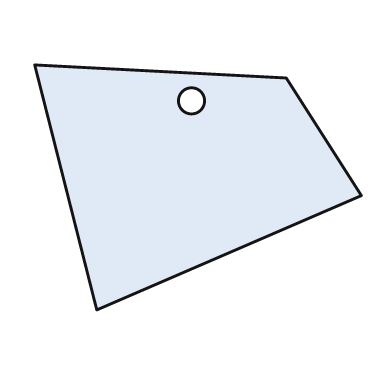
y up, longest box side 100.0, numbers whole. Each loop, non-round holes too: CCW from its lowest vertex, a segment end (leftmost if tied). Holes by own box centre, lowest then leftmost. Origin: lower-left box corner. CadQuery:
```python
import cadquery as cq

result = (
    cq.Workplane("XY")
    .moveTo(19.0, 0.0)
    .lineTo(100.0, 35.0)
    .lineTo(77.0, 71.0)
    .lineTo(0.0, 75.0)
    .close()
    .moveTo(48.0, 64.0)
    .circle(4.0)
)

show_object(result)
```